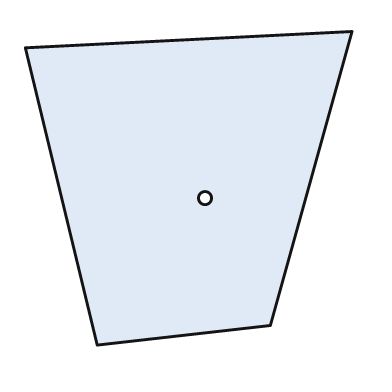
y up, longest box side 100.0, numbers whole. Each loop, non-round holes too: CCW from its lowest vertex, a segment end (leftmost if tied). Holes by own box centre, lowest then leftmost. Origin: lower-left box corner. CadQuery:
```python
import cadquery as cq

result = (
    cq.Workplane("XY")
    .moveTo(22.0, 0.0)
    .lineTo(75.0, 6.0)
    .lineTo(100.0, 96.0)
    .lineTo(0.0, 91.0)
    .close()
    .moveTo(55.0, 45.0)
    .circle(2.0)
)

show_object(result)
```